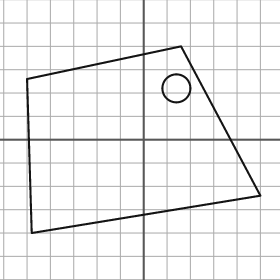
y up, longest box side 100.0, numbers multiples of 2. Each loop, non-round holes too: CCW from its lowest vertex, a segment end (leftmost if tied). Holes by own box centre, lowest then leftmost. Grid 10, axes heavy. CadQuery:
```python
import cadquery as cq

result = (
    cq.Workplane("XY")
    .moveTo(-48.0, -40.0)
    .lineTo(50.0, -24.0)
    .lineTo(16.0, 40.0)
    .lineTo(-50.0, 26.0)
    .close()
    .moveTo(14.0, 22.0)
    .circle(6.0)
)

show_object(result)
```